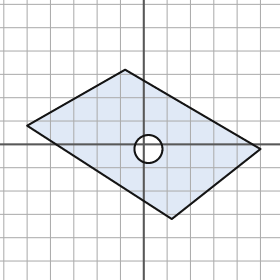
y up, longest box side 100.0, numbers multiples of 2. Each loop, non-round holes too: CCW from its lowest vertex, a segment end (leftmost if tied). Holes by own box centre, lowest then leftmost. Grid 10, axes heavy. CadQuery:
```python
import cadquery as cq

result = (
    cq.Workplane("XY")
    .moveTo(12.0, -32.0)
    .lineTo(50.0, -2.0)
    .lineTo(-8.0, 32.0)
    .lineTo(-50.0, 8.0)
    .close()
    .moveTo(2.0, -2.0)
    .circle(6.0)
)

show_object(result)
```